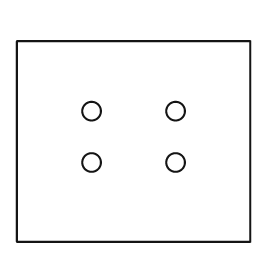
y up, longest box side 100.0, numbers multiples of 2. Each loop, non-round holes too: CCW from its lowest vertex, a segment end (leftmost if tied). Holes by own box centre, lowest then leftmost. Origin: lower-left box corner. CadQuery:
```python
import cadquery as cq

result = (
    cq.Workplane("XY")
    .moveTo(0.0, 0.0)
    .lineTo(100.0, 0.0)
    .lineTo(100.0, 86.0)
    .lineTo(0.0, 86.0)
    .close()
    .moveTo(32.0, 34.0)
    .circle(4.0)
    .moveTo(68.0, 34.0)
    .circle(4.0)
    .moveTo(32.0, 56.0)
    .circle(4.0)
    .moveTo(68.0, 56.0)
    .circle(4.0)
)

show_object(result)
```